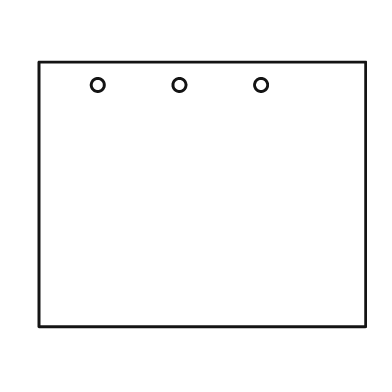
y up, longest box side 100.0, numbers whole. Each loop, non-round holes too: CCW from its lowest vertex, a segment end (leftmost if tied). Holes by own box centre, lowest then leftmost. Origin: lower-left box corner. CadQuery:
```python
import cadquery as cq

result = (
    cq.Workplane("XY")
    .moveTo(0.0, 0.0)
    .lineTo(100.0, 0.0)
    .lineTo(100.0, 81.0)
    .lineTo(0.0, 81.0)
    .close()
    .moveTo(18.0, 74.0)
    .circle(2.0)
    .moveTo(43.0, 74.0)
    .circle(2.0)
    .moveTo(68.0, 74.0)
    .circle(2.0)
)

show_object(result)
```